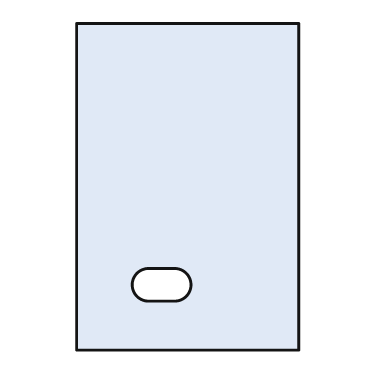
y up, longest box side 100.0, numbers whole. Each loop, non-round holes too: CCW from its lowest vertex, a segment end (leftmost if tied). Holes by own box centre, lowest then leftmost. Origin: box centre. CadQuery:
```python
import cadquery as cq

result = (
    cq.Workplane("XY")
    .moveTo(-34.0, -50.0)
    .lineTo(34.0, -50.0)
    .lineTo(34.0, 50.0)
    .lineTo(-34.0, 50.0)
    .close()
    .moveTo(-12.0, -35.0)
    .lineTo(-4.0, -35.0)
    .threePointArc((1.0, -30.0), (-4.0, -25.0))
    .lineTo(-12.0, -25.0)
    .threePointArc((-17.0, -30.0), (-12.0, -35.0))
    .close()
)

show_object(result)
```